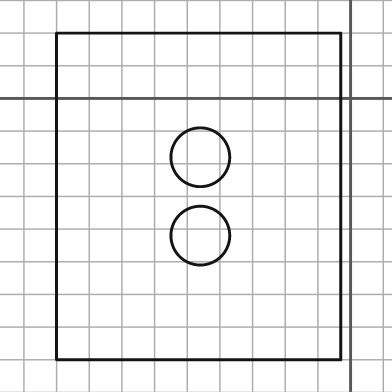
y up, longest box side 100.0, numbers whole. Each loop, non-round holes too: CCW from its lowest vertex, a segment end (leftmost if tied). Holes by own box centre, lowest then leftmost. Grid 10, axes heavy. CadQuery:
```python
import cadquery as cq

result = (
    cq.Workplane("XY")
    .moveTo(-90.0, -80.0)
    .lineTo(-3.0, -80.0)
    .lineTo(-3.0, 20.0)
    .lineTo(-90.0, 20.0)
    .close()
    .moveTo(-46.0, -42.0)
    .circle(9.0)
    .moveTo(-46.0, -18.0)
    .circle(9.0)
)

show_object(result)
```